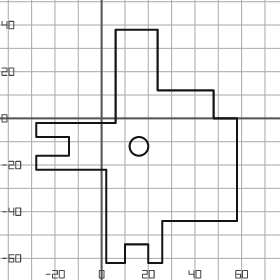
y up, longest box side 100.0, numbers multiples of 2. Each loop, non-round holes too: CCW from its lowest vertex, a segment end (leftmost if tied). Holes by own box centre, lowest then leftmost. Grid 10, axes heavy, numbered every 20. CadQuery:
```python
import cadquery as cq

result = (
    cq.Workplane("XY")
    .moveTo(2.0, -62.0)
    .lineTo(10.0, -62.0)
    .lineTo(10.0, -54.0)
    .lineTo(20.0, -54.0)
    .lineTo(20.0, -62.0)
    .lineTo(26.0, -62.0)
    .lineTo(26.0, -44.0)
    .lineTo(58.0, -44.0)
    .lineTo(58.0, 0.0)
    .lineTo(48.0, 0.0)
    .lineTo(48.0, 12.0)
    .lineTo(24.0, 12.0)
    .lineTo(24.0, 38.0)
    .lineTo(6.0, 38.0)
    .lineTo(6.0, -2.0)
    .lineTo(-28.0, -2.0)
    .lineTo(-28.0, -8.0)
    .lineTo(-14.0, -8.0)
    .lineTo(-14.0, -16.0)
    .lineTo(-28.0, -16.0)
    .lineTo(-28.0, -22.0)
    .lineTo(2.0, -22.0)
    .close()
    .moveTo(16.0, -12.0)
    .circle(4.0)
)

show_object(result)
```